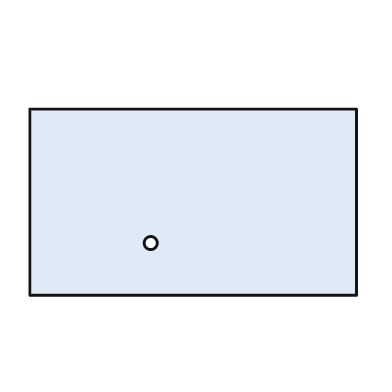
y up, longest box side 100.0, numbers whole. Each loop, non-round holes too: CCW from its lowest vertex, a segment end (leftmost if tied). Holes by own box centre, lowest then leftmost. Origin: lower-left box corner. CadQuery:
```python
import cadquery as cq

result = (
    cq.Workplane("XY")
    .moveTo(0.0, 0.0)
    .lineTo(100.0, 0.0)
    .lineTo(100.0, 57.0)
    .lineTo(0.0, 57.0)
    .close()
    .moveTo(37.0, 16.0)
    .circle(2.0)
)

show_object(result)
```